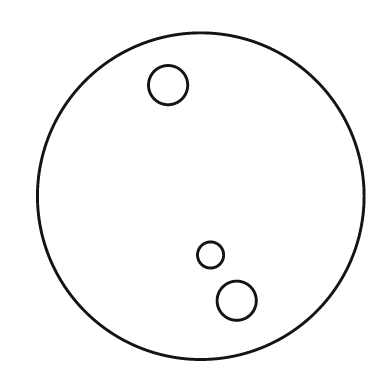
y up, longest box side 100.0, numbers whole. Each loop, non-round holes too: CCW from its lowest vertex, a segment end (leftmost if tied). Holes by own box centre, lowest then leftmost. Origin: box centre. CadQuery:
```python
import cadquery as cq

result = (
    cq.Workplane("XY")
    .moveTo(0.0, 0.0)
    .circle(50.0)
    .moveTo(11.0, -32.0)
    .circle(6.0)
    .moveTo(3.0, -18.0)
    .circle(4.0)
    .moveTo(-10.0, 34.0)
    .circle(6.0)
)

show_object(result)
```